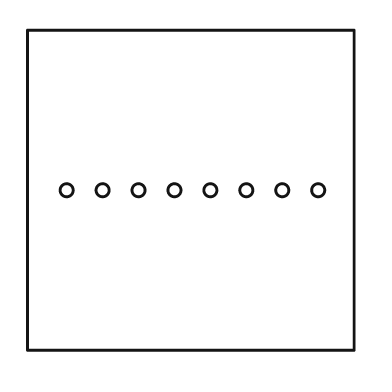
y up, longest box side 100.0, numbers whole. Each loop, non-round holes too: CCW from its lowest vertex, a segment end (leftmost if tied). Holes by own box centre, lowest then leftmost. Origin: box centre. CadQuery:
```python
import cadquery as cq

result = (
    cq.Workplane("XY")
    .moveTo(-50.0, -49.0)
    .lineTo(50.0, -49.0)
    .lineTo(50.0, 49.0)
    .lineTo(-50.0, 49.0)
    .close()
    .moveTo(-38.0, 0.0)
    .circle(2.0)
    .moveTo(-27.0, 0.0)
    .circle(2.0)
    .moveTo(-16.0, 0.0)
    .circle(2.0)
    .moveTo(-5.0, 0.0)
    .circle(2.0)
    .moveTo(6.0, 0.0)
    .circle(2.0)
    .moveTo(17.0, 0.0)
    .circle(2.0)
    .moveTo(28.0, 0.0)
    .circle(2.0)
    .moveTo(39.0, 0.0)
    .circle(2.0)
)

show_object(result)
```